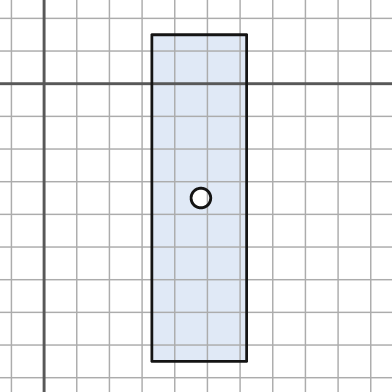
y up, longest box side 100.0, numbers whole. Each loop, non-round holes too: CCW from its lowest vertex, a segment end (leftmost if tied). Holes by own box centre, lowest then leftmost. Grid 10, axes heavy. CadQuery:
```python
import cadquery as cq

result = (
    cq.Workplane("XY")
    .moveTo(33.0, -85.0)
    .lineTo(62.0, -85.0)
    .lineTo(62.0, 15.0)
    .lineTo(33.0, 15.0)
    .close()
    .moveTo(48.0, -35.0)
    .circle(3.0)
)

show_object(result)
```